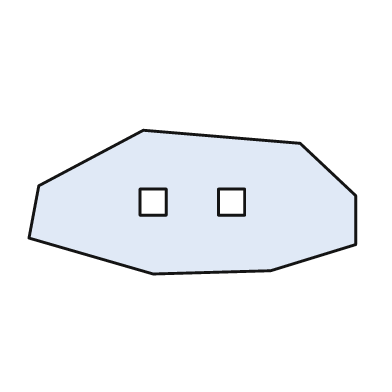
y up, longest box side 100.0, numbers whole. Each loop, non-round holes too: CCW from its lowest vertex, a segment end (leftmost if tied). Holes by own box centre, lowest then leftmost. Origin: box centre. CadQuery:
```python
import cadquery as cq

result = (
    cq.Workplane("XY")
    .moveTo(-12.0, -22.0)
    .lineTo(24.0, -21.0)
    .lineTo(50.0, -13.0)
    .lineTo(50.0, 2.0)
    .lineTo(33.0, 18.0)
    .lineTo(-15.0, 22.0)
    .lineTo(-47.0, 5.0)
    .lineTo(-50.0, -11.0)
    .close()
    .moveTo(-16.0, -4.0)
    .lineTo(-8.0, -4.0)
    .lineTo(-8.0, 4.0)
    .lineTo(-16.0, 4.0)
    .close()
    .moveTo(8.0, -4.0)
    .lineTo(16.0, -4.0)
    .lineTo(16.0, 4.0)
    .lineTo(8.0, 4.0)
    .close()
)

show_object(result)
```